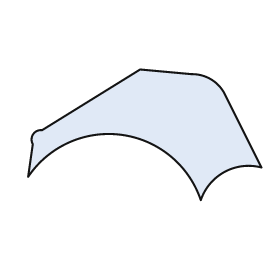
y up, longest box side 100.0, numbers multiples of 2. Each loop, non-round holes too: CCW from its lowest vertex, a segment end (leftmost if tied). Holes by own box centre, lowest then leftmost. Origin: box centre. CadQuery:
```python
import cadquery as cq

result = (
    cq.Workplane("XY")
    .moveTo(24.0, -28.0)
    .threePointArc((34.0, -16.0), (50.0, -14.0))
    .lineTo(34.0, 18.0)
    .threePointArc((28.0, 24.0), (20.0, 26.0))
    .lineTo(-2.0, 28.0)
    .lineTo(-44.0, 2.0)
    .threePointArc((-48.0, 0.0), (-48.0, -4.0))
    .lineTo(-50.0, -18.0)
    .threePointArc((-10.0, 0.0), (24.0, -28.0))
    .close()
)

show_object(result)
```